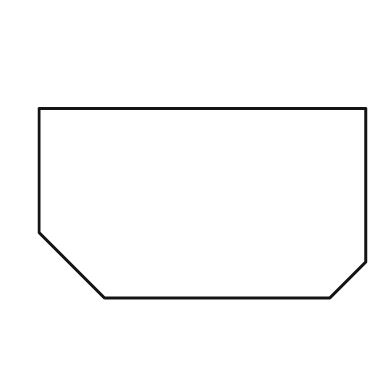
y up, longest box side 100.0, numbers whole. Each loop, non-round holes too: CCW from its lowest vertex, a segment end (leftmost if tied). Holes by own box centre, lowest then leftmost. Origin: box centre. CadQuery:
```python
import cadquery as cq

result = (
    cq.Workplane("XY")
    .moveTo(-30.0, -29.0)
    .lineTo(39.0, -29.0)
    .lineTo(50.0, -18.0)
    .lineTo(50.0, 29.0)
    .lineTo(-50.0, 29.0)
    .lineTo(-50.0, -9.0)
    .close()
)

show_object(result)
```